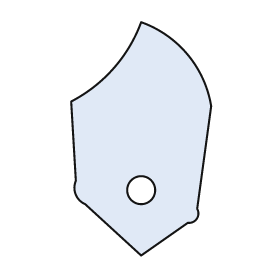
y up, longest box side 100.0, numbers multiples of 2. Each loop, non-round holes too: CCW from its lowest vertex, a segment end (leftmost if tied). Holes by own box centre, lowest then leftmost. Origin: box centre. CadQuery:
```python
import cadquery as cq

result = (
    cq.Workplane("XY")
    .moveTo(0.0, -50.0)
    .lineTo(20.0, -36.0)
    .threePointArc((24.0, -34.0), (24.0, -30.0))
    .lineTo(30.0, 14.0)
    .threePointArc((20.0, 36.0), (0.0, 50.0))
    .threePointArc((-12.0, 30.0), (-30.0, 16.0))
    .lineTo(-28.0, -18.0)
    .threePointArc((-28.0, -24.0), (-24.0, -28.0))
    .close()
    .moveTo(0.0, -22.0)
    .circle(6.0)
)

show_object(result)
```